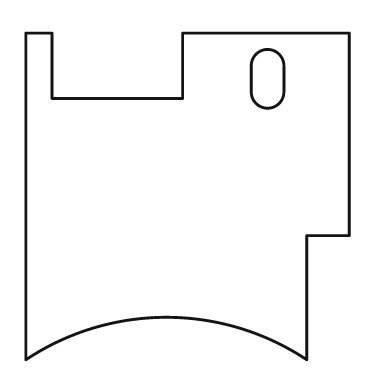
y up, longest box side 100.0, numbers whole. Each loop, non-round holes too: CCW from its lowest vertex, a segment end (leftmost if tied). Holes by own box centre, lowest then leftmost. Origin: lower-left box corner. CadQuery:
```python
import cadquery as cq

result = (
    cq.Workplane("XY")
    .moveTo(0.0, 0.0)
    .threePointArc((43.0, 13.0), (86.0, 0.0))
    .lineTo(86.0, 38.0)
    .lineTo(99.0, 38.0)
    .lineTo(99.0, 100.0)
    .lineTo(48.0, 100.0)
    .lineTo(48.0, 80.0)
    .lineTo(8.0, 80.0)
    .lineTo(8.0, 100.0)
    .lineTo(0.0, 100.0)
    .close()
    .moveTo(69.0, 82.0)
    .threePointArc((74.0, 77.0), (79.0, 82.0))
    .lineTo(79.0, 90.0)
    .threePointArc((74.0, 95.0), (69.0, 90.0))
    .close()
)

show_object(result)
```